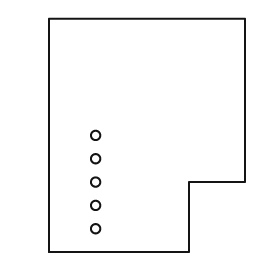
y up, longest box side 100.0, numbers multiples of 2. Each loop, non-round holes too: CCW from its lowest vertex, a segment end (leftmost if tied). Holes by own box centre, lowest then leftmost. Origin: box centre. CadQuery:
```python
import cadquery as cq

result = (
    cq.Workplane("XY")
    .moveTo(-42.0, -50.0)
    .lineTo(18.0, -50.0)
    .lineTo(18.0, -20.0)
    .lineTo(42.0, -20.0)
    .lineTo(42.0, 50.0)
    .lineTo(-42.0, 50.0)
    .close()
    .moveTo(-22.0, -40.0)
    .circle(2.0)
    .moveTo(-22.0, -30.0)
    .circle(2.0)
    .moveTo(-22.0, -20.0)
    .circle(2.0)
    .moveTo(-22.0, -10.0)
    .circle(2.0)
    .moveTo(-22.0, 0.0)
    .circle(2.0)
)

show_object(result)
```